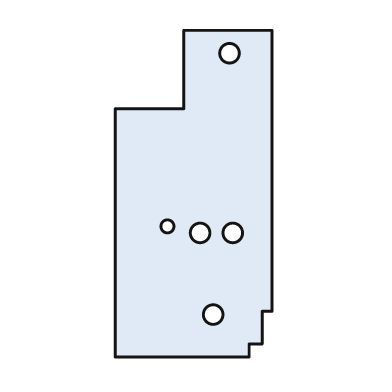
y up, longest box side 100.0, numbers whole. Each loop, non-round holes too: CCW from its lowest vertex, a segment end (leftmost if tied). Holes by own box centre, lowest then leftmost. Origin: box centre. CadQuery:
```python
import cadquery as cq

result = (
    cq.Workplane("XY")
    .moveTo(-24.0, -50.0)
    .lineTo(17.0, -50.0)
    .lineTo(17.0, -46.0)
    .lineTo(21.0, -46.0)
    .lineTo(21.0, -36.0)
    .lineTo(24.0, -36.0)
    .lineTo(24.0, 50.0)
    .lineTo(-3.0, 50.0)
    .lineTo(-3.0, 26.0)
    .lineTo(-24.0, 26.0)
    .close()
    .moveTo(6.0, -37.0)
    .circle(3.0)
    .moveTo(2.0, -12.0)
    .circle(3.0)
    .moveTo(12.0, -12.0)
    .circle(3.0)
    .moveTo(-8.0, -10.0)
    .circle(2.0)
    .moveTo(11.0, 43.0)
    .circle(3.0)
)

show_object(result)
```